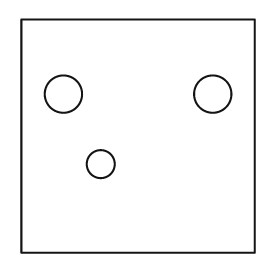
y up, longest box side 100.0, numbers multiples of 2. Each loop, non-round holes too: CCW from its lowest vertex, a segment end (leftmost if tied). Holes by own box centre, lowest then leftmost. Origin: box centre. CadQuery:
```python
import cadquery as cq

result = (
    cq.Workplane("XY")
    .moveTo(-50.0, -50.0)
    .lineTo(50.0, -50.0)
    .lineTo(50.0, 50.0)
    .lineTo(-50.0, 50.0)
    .close()
    .moveTo(-16.0, -12.0)
    .circle(6.0)
    .moveTo(-32.0, 18.0)
    .circle(8.0)
    .moveTo(32.0, 18.0)
    .circle(8.0)
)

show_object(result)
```